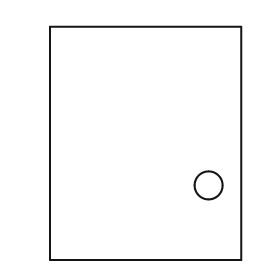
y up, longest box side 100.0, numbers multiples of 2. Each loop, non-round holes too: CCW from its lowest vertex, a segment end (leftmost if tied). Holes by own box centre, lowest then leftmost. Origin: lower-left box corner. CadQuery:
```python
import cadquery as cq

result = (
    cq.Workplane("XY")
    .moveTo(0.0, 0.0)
    .lineTo(82.0, 0.0)
    .lineTo(82.0, 100.0)
    .lineTo(0.0, 100.0)
    .close()
    .moveTo(68.0, 32.0)
    .circle(6.0)
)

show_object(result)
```